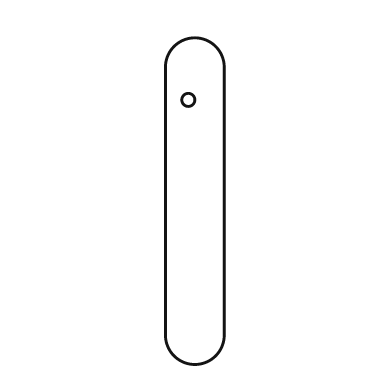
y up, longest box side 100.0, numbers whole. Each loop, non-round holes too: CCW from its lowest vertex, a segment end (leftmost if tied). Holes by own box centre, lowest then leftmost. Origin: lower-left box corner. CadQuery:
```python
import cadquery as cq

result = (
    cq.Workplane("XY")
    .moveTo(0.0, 9.0)
    .threePointArc((9.0, 0.0), (18.0, 9.0))
    .lineTo(18.0, 91.0)
    .threePointArc((9.0, 100.0), (0.0, 91.0))
    .close()
    .moveTo(7.0, 81.0)
    .circle(2.0)
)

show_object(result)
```